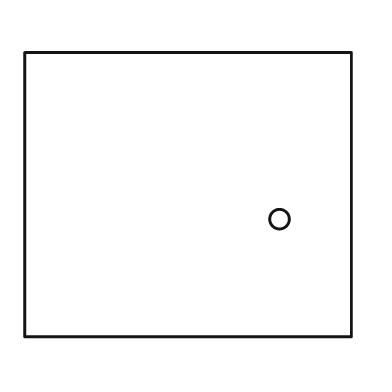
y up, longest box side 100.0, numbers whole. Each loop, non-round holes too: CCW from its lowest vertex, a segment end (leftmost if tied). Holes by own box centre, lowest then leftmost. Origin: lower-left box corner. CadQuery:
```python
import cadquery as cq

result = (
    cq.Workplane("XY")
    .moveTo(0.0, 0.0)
    .lineTo(100.0, 0.0)
    .lineTo(100.0, 87.0)
    .lineTo(0.0, 87.0)
    .close()
    .moveTo(78.0, 36.0)
    .circle(3.0)
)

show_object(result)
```